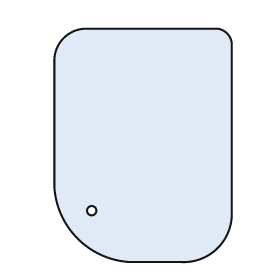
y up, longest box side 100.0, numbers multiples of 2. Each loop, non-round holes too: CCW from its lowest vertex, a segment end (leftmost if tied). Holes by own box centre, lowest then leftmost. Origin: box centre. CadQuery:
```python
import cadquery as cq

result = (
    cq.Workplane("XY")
    .moveTo(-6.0, -50.0)
    .lineTo(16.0, -50.0)
    .threePointArc((32.0, -44.0), (38.0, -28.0))
    .lineTo(38.0, 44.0)
    .threePointArc((36.0, 48.0), (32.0, 50.0))
    .lineTo(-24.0, 50.0)
    .threePointArc((-34.0, 46.0), (-38.0, 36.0))
    .lineTo(-38.0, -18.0)
    .threePointArc((-28.0, -40.0), (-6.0, -50.0))
    .close()
    .moveTo(-22.0, -28.0)
    .circle(2.0)
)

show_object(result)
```